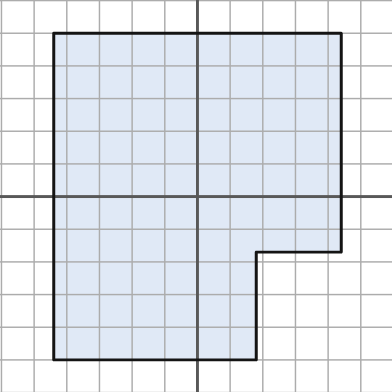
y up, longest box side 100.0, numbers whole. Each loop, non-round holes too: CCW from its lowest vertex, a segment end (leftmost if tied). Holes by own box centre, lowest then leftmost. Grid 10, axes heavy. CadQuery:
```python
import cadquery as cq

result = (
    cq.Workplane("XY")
    .moveTo(-44.0, -50.0)
    .lineTo(18.0, -50.0)
    .lineTo(18.0, -17.0)
    .lineTo(44.0, -17.0)
    .lineTo(44.0, 50.0)
    .lineTo(-44.0, 50.0)
    .close()
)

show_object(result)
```